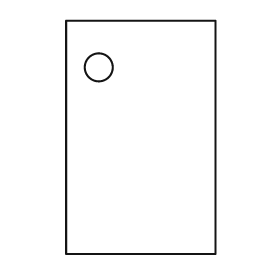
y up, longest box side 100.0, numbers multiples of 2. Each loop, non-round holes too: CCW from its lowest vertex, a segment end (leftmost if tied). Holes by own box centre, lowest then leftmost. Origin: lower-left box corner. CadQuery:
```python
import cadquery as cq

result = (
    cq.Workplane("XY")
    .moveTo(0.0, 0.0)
    .lineTo(64.0, 0.0)
    .lineTo(64.0, 100.0)
    .lineTo(0.0, 100.0)
    .close()
    .moveTo(14.0, 80.0)
    .circle(6.0)
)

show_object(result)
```